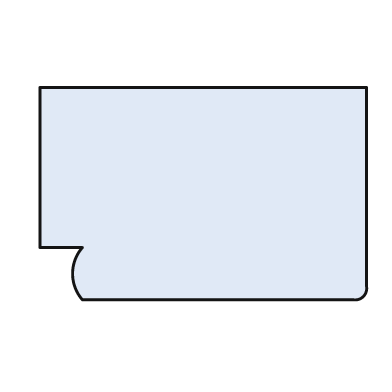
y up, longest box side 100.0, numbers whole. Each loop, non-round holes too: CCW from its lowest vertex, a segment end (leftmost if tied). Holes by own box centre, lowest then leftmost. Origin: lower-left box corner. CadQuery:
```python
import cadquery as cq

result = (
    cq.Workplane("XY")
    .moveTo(13.0, 0.0)
    .lineTo(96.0, 0.0)
    .threePointArc((99.0, 1.0), (100.0, 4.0))
    .lineTo(100.0, 65.0)
    .lineTo(0.0, 65.0)
    .lineTo(0.0, 16.0)
    .lineTo(13.0, 16.0)
    .threePointArc((10.0, 8.0), (13.0, 0.0))
    .close()
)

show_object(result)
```